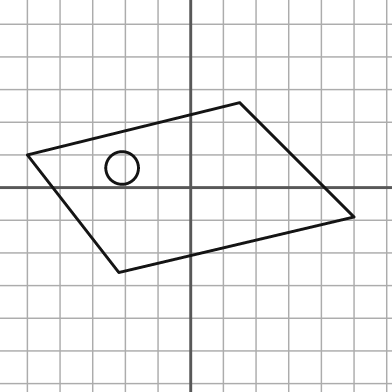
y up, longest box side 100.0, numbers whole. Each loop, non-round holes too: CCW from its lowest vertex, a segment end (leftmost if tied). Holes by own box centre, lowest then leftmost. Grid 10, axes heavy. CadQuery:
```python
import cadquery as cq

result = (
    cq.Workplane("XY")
    .moveTo(-22.0, -26.0)
    .lineTo(50.0, -9.0)
    .lineTo(15.0, 26.0)
    .lineTo(-50.0, 10.0)
    .close()
    .moveTo(-21.0, 6.0)
    .circle(5.0)
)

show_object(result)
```